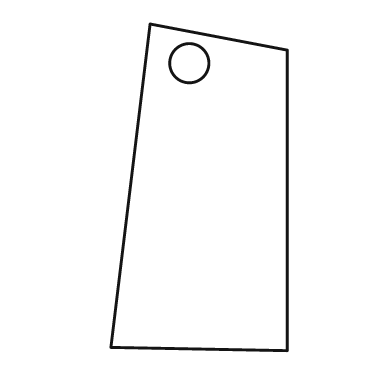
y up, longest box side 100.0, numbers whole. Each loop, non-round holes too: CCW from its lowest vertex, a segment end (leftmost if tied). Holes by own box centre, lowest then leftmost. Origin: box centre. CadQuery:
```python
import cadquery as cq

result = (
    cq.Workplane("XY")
    .moveTo(27.0, -50.0)
    .lineTo(27.0, 42.0)
    .lineTo(-15.0, 50.0)
    .lineTo(-27.0, -49.0)
    .close()
    .moveTo(-3.0, 38.0)
    .circle(6.0)
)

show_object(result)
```